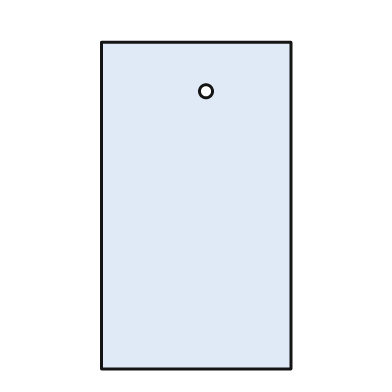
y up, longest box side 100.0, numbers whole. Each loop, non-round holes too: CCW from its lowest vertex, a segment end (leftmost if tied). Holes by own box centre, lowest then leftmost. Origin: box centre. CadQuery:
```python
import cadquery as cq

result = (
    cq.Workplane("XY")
    .moveTo(-29.0, -50.0)
    .lineTo(29.0, -50.0)
    .lineTo(29.0, 50.0)
    .lineTo(-29.0, 50.0)
    .close()
    .moveTo(3.0, 35.0)
    .circle(2.0)
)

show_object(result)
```